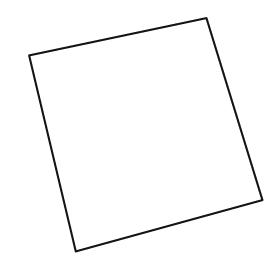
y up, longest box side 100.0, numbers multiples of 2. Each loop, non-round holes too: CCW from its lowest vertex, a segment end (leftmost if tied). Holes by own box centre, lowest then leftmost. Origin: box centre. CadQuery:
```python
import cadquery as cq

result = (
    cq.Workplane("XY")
    .moveTo(-30.0, -50.0)
    .lineTo(50.0, -28.0)
    .lineTo(26.0, 50.0)
    .lineTo(-50.0, 34.0)
    .close()
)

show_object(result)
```